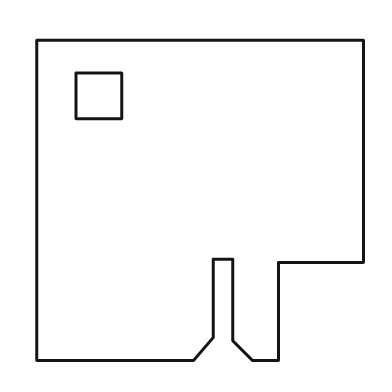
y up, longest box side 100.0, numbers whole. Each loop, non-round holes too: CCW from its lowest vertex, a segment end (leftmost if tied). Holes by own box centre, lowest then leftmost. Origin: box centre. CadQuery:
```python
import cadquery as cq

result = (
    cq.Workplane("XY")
    .moveTo(-50.0, -49.0)
    .lineTo(-2.0, -49.0)
    .lineTo(4.0, -42.0)
    .lineTo(4.0, -18.0)
    .lineTo(10.0, -18.0)
    .lineTo(10.0, -43.0)
    .lineTo(16.0, -49.0)
    .lineTo(24.0, -49.0)
    .lineTo(24.0, -19.0)
    .lineTo(50.0, -19.0)
    .lineTo(50.0, 49.0)
    .lineTo(-50.0, 49.0)
    .close()
    .moveTo(-38.0, 25.0)
    .lineTo(-24.0, 25.0)
    .lineTo(-24.0, 39.0)
    .lineTo(-38.0, 39.0)
    .close()
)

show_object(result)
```